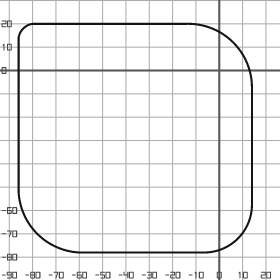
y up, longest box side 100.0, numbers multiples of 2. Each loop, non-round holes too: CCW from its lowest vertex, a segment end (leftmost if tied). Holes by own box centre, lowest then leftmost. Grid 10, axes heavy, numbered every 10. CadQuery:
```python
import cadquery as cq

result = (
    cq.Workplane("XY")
    .moveTo(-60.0, -78.0)
    .lineTo(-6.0, -78.0)
    .threePointArc((8.0, -72.0), (14.0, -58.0))
    .lineTo(14.0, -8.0)
    .threePointArc((6.0, 12.0), (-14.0, 20.0))
    .lineTo(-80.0, 20.0)
    .threePointArc((-84.0, 18.0), (-86.0, 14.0))
    .lineTo(-86.0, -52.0)
    .threePointArc((-78.0, -70.0), (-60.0, -78.0))
    .close()
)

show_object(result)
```